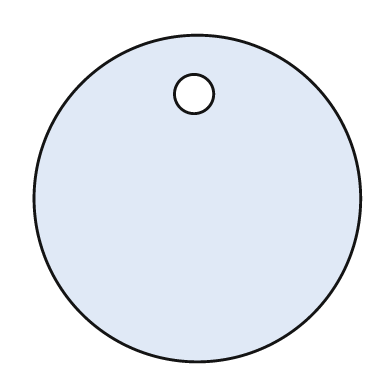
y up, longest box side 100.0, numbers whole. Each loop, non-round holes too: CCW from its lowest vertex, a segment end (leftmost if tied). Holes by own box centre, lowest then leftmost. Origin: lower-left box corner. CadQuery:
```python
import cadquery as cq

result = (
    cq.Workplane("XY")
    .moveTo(50.0, 50.0)
    .circle(50.0)
    .moveTo(49.0, 82.0)
    .circle(6.0)
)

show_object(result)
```